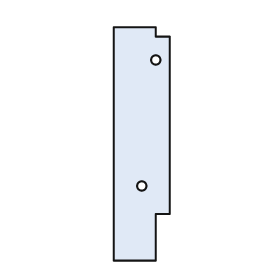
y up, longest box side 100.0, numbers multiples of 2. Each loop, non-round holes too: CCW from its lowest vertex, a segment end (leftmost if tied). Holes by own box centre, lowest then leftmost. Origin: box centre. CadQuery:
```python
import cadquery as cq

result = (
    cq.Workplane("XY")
    .moveTo(-12.0, -50.0)
    .lineTo(6.0, -50.0)
    .lineTo(6.0, -30.0)
    .lineTo(12.0, -30.0)
    .lineTo(12.0, 46.0)
    .lineTo(6.0, 46.0)
    .lineTo(6.0, 50.0)
    .lineTo(-12.0, 50.0)
    .close()
    .moveTo(0.0, -18.0)
    .circle(2.0)
    .moveTo(6.0, 36.0)
    .circle(2.0)
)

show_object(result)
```